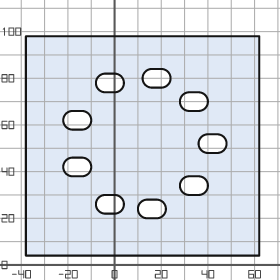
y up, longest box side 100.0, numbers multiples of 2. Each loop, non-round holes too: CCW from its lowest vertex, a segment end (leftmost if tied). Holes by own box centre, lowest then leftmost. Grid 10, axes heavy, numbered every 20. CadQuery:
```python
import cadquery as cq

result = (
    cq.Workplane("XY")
    .moveTo(-38.0, 4.0)
    .lineTo(62.0, 4.0)
    .lineTo(62.0, 98.0)
    .lineTo(-38.0, 98.0)
    .close()
    .moveTo(14.0, 20.0)
    .lineTo(18.0, 20.0)
    .threePointArc((22.0, 24.0), (18.0, 28.0))
    .lineTo(14.0, 28.0)
    .threePointArc((10.0, 24.0), (14.0, 20.0))
    .close()
    .moveTo(-4.0, 22.0)
    .lineTo(0.0, 22.0)
    .threePointArc((4.0, 26.0), (0.0, 30.0))
    .lineTo(-4.0, 30.0)
    .threePointArc((-8.0, 26.0), (-4.0, 22.0))
    .close()
    .moveTo(32.0, 30.0)
    .lineTo(36.0, 30.0)
    .threePointArc((40.0, 34.0), (36.0, 38.0))
    .lineTo(32.0, 38.0)
    .threePointArc((28.0, 34.0), (32.0, 30.0))
    .close()
    .moveTo(-18.0, 38.0)
    .lineTo(-14.0, 38.0)
    .threePointArc((-10.0, 42.0), (-14.0, 46.0))
    .lineTo(-18.0, 46.0)
    .threePointArc((-22.0, 42.0), (-18.0, 38.0))
    .close()
    .moveTo(40.0, 48.0)
    .lineTo(44.0, 48.0)
    .threePointArc((48.0, 52.0), (44.0, 56.0))
    .lineTo(40.0, 56.0)
    .threePointArc((36.0, 52.0), (40.0, 48.0))
    .close()
    .moveTo(-18.0, 58.0)
    .lineTo(-14.0, 58.0)
    .threePointArc((-10.0, 62.0), (-14.0, 66.0))
    .lineTo(-18.0, 66.0)
    .threePointArc((-22.0, 62.0), (-18.0, 58.0))
    .close()
    .moveTo(32.0, 66.0)
    .lineTo(36.0, 66.0)
    .threePointArc((40.0, 70.0), (36.0, 74.0))
    .lineTo(32.0, 74.0)
    .threePointArc((28.0, 70.0), (32.0, 66.0))
    .close()
    .moveTo(-4.0, 74.0)
    .lineTo(0.0, 74.0)
    .threePointArc((4.0, 78.0), (0.0, 82.0))
    .lineTo(-4.0, 82.0)
    .threePointArc((-8.0, 78.0), (-4.0, 74.0))
    .close()
    .moveTo(16.0, 76.0)
    .lineTo(20.0, 76.0)
    .threePointArc((24.0, 80.0), (20.0, 84.0))
    .lineTo(16.0, 84.0)
    .threePointArc((12.0, 80.0), (16.0, 76.0))
    .close()
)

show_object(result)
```